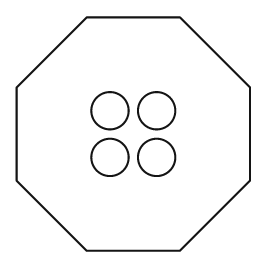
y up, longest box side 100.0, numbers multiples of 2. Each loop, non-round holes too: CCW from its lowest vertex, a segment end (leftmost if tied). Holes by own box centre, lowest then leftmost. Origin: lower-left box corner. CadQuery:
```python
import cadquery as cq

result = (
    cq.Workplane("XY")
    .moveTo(30.0, 0.0)
    .lineTo(70.0, 0.0)
    .lineTo(100.0, 30.0)
    .lineTo(100.0, 70.0)
    .lineTo(70.0, 100.0)
    .lineTo(30.0, 100.0)
    .lineTo(0.0, 70.0)
    .lineTo(0.0, 30.0)
    .close()
    .moveTo(40.0, 40.0)
    .circle(8.0)
    .moveTo(60.0, 40.0)
    .circle(8.0)
    .moveTo(40.0, 60.0)
    .circle(8.0)
    .moveTo(60.0, 60.0)
    .circle(8.0)
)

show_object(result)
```